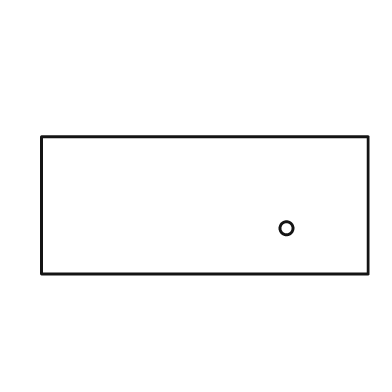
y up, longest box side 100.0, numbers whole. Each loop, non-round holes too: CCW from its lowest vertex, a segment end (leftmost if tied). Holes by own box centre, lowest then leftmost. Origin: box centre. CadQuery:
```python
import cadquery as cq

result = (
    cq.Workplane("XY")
    .moveTo(-50.0, -21.0)
    .lineTo(50.0, -21.0)
    .lineTo(50.0, 21.0)
    .lineTo(-50.0, 21.0)
    .close()
    .moveTo(25.0, -7.0)
    .circle(2.0)
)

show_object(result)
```